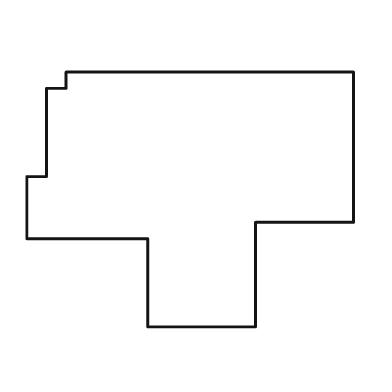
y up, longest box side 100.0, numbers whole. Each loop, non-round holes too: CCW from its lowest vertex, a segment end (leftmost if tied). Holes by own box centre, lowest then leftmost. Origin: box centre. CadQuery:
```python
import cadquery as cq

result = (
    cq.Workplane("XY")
    .moveTo(-13.0, -39.0)
    .lineTo(20.0, -39.0)
    .lineTo(20.0, -7.0)
    .lineTo(50.0, -7.0)
    .lineTo(50.0, 39.0)
    .lineTo(-38.0, 39.0)
    .lineTo(-38.0, 34.0)
    .lineTo(-44.0, 34.0)
    .lineTo(-44.0, 7.0)
    .lineTo(-50.0, 7.0)
    .lineTo(-50.0, -12.0)
    .lineTo(-13.0, -12.0)
    .close()
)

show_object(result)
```